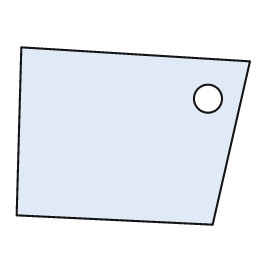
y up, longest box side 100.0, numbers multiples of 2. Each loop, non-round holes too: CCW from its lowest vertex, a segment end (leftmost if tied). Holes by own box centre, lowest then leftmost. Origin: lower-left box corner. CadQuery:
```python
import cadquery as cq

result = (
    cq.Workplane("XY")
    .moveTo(84.0, 0.0)
    .lineTo(100.0, 70.0)
    .lineTo(2.0, 76.0)
    .lineTo(0.0, 4.0)
    .close()
    .moveTo(82.0, 54.0)
    .circle(6.0)
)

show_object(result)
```